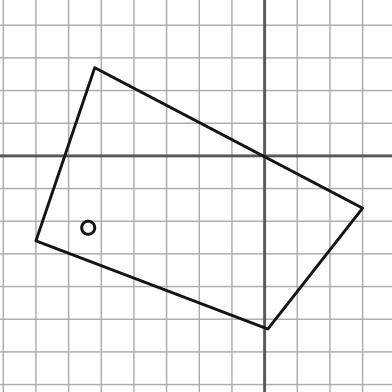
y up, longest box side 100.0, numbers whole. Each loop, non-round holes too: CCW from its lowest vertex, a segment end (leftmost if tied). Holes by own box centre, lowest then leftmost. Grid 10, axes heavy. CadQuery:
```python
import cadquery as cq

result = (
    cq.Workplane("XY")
    .moveTo(1.0, -53.0)
    .lineTo(30.0, -16.0)
    .lineTo(-52.0, 27.0)
    .lineTo(-70.0, -26.0)
    .close()
    .moveTo(-54.0, -22.0)
    .circle(2.0)
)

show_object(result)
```